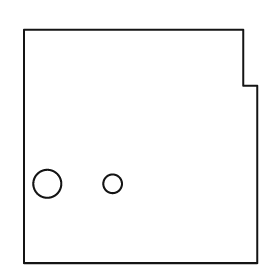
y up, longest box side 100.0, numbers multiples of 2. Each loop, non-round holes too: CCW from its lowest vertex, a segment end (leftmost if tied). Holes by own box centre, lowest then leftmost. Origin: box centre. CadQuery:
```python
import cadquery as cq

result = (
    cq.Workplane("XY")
    .moveTo(-50.0, -50.0)
    .lineTo(50.0, -50.0)
    .lineTo(50.0, 26.0)
    .lineTo(44.0, 26.0)
    .lineTo(44.0, 50.0)
    .lineTo(-50.0, 50.0)
    .close()
    .moveTo(-40.0, -16.0)
    .circle(6.0)
    .moveTo(-12.0, -16.0)
    .circle(4.0)
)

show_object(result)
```